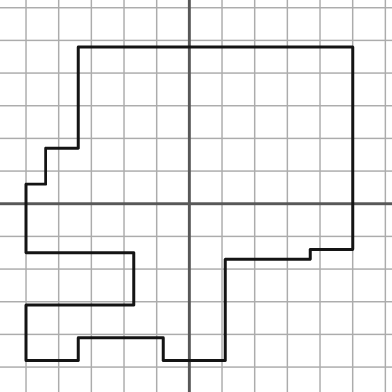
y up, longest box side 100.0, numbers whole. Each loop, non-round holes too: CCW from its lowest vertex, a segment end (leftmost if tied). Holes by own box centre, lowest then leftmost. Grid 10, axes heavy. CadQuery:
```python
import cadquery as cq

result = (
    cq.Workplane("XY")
    .moveTo(-50.0, -48.0)
    .lineTo(-34.0, -48.0)
    .lineTo(-34.0, -41.0)
    .lineTo(-8.0, -41.0)
    .lineTo(-8.0, -48.0)
    .lineTo(11.0, -48.0)
    .lineTo(11.0, -17.0)
    .lineTo(37.0, -17.0)
    .lineTo(37.0, -14.0)
    .lineTo(50.0, -14.0)
    .lineTo(50.0, 48.0)
    .lineTo(-34.0, 48.0)
    .lineTo(-34.0, 17.0)
    .lineTo(-44.0, 17.0)
    .lineTo(-44.0, 6.0)
    .lineTo(-50.0, 6.0)
    .lineTo(-50.0, -15.0)
    .lineTo(-17.0, -15.0)
    .lineTo(-17.0, -31.0)
    .lineTo(-50.0, -31.0)
    .close()
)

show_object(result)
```